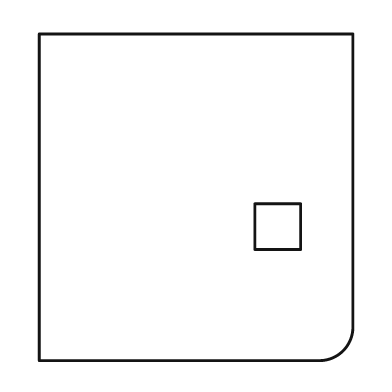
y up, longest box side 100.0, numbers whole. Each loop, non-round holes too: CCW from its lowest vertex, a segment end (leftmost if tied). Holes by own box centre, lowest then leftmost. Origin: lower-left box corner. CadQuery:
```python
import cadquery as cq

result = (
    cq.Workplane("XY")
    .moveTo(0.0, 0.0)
    .lineTo(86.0, 0.0)
    .threePointArc((93.0, 3.0), (96.0, 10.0))
    .lineTo(96.0, 100.0)
    .lineTo(0.0, 100.0)
    .close()
    .moveTo(66.0, 34.0)
    .lineTo(80.0, 34.0)
    .lineTo(80.0, 48.0)
    .lineTo(66.0, 48.0)
    .close()
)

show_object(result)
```